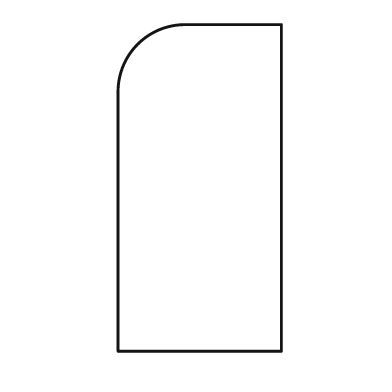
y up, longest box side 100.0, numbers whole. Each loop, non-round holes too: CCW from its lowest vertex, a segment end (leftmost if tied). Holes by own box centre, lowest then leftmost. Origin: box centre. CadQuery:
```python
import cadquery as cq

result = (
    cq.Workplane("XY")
    .moveTo(-25.0, -50.0)
    .lineTo(25.0, -50.0)
    .lineTo(25.0, 50.0)
    .lineTo(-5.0, 50.0)
    .threePointArc((-19.0, 44.0), (-25.0, 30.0))
    .close()
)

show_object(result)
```